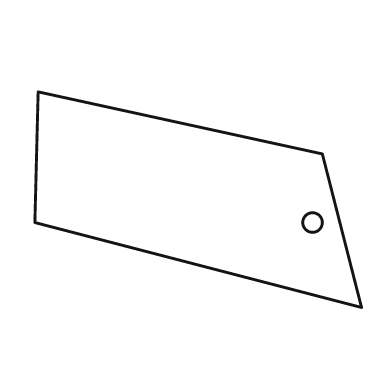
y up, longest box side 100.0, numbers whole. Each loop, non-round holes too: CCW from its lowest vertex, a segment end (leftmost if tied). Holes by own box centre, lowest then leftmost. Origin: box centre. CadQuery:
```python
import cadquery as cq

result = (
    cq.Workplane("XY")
    .moveTo(50.0, -33.0)
    .lineTo(38.0, 14.0)
    .lineTo(-49.0, 33.0)
    .lineTo(-50.0, -7.0)
    .close()
    .moveTo(35.0, -7.0)
    .circle(3.0)
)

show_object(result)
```